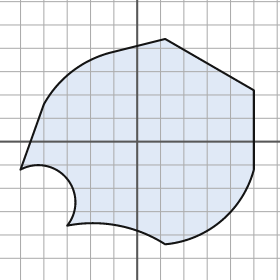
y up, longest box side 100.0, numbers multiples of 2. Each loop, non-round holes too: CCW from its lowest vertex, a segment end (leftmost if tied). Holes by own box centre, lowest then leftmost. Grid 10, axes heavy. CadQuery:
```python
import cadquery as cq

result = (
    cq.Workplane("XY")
    .moveTo(12.0, -44.0)
    .threePointArc((36.0, -34.0), (50.0, -12.0))
    .lineTo(50.0, 22.0)
    .lineTo(12.0, 44.0)
    .lineTo(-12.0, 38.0)
    .threePointArc((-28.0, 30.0), (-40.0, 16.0))
    .lineTo(-50.0, -12.0)
    .threePointArc((-30.0, -16.0), (-30.0, -36.0))
    .threePointArc((-8.0, -36.0), (12.0, -44.0))
    .close()
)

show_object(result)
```